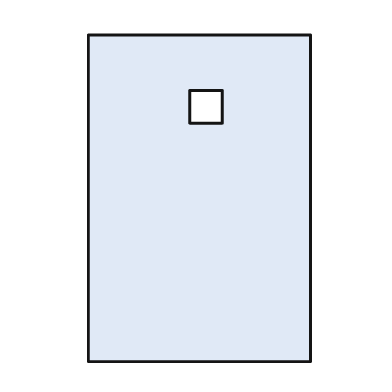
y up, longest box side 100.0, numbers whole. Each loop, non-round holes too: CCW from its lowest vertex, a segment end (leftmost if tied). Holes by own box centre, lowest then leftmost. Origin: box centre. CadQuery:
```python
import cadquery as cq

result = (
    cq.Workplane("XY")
    .moveTo(-34.0, -50.0)
    .lineTo(34.0, -50.0)
    .lineTo(34.0, 50.0)
    .lineTo(-34.0, 50.0)
    .close()
    .moveTo(-3.0, 23.0)
    .lineTo(7.0, 23.0)
    .lineTo(7.0, 33.0)
    .lineTo(-3.0, 33.0)
    .close()
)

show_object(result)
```